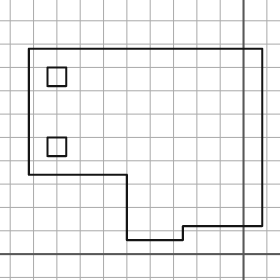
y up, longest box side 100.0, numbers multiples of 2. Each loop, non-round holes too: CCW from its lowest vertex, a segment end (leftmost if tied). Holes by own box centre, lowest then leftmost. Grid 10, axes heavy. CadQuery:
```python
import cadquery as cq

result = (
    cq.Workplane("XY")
    .moveTo(-50.0, 6.0)
    .lineTo(-26.0, 6.0)
    .lineTo(-26.0, 12.0)
    .lineTo(8.0, 12.0)
    .lineTo(8.0, 88.0)
    .lineTo(-92.0, 88.0)
    .lineTo(-92.0, 34.0)
    .lineTo(-50.0, 34.0)
    .close()
    .moveTo(-84.0, 42.0)
    .lineTo(-76.0, 42.0)
    .lineTo(-76.0, 50.0)
    .lineTo(-84.0, 50.0)
    .close()
    .moveTo(-84.0, 72.0)
    .lineTo(-76.0, 72.0)
    .lineTo(-76.0, 80.0)
    .lineTo(-84.0, 80.0)
    .close()
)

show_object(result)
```